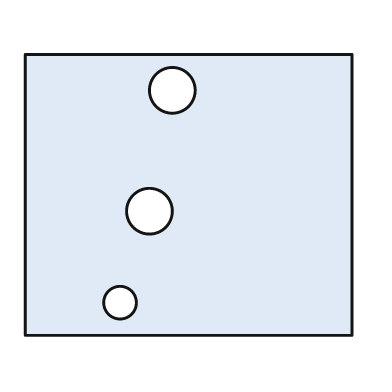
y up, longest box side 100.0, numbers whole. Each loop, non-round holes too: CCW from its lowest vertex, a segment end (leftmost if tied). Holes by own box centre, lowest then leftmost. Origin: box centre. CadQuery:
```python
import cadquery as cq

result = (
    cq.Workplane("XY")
    .moveTo(-50.0, -43.0)
    .lineTo(50.0, -43.0)
    .lineTo(50.0, 43.0)
    .lineTo(-50.0, 43.0)
    .close()
    .moveTo(-21.0, -33.0)
    .circle(5.0)
    .moveTo(-12.0, -5.0)
    .circle(7.0)
    .moveTo(-5.0, 32.0)
    .circle(7.0)
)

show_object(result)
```